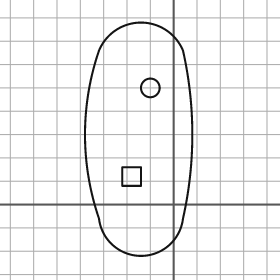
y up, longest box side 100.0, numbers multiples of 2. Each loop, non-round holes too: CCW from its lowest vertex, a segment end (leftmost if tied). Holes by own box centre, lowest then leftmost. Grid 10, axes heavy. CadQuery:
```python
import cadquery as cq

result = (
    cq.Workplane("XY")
    .moveTo(-32.0, -6.0)
    .threePointArc((-14.0, -22.0), (4.0, -6.0))
    .threePointArc((8.0, 30.0), (4.0, 66.0))
    .threePointArc((-14.0, 78.0), (-32.0, 66.0))
    .threePointArc((-38.0, 30.0), (-32.0, -6.0))
    .close()
    .moveTo(-22.0, 8.0)
    .lineTo(-14.0, 8.0)
    .lineTo(-14.0, 16.0)
    .lineTo(-22.0, 16.0)
    .close()
    .moveTo(-10.0, 50.0)
    .circle(4.0)
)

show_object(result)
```